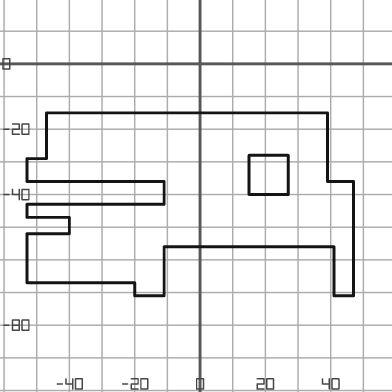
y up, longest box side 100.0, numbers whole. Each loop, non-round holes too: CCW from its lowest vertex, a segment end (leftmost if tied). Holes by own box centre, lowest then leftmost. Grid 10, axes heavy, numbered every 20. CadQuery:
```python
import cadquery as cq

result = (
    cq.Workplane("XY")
    .moveTo(-20.0, -71.0)
    .lineTo(-11.0, -71.0)
    .lineTo(-11.0, -56.0)
    .lineTo(41.0, -56.0)
    .lineTo(41.0, -71.0)
    .lineTo(47.0, -71.0)
    .lineTo(47.0, -36.0)
    .lineTo(39.0, -36.0)
    .lineTo(39.0, -15.0)
    .lineTo(-47.0, -15.0)
    .lineTo(-47.0, -29.0)
    .lineTo(-53.0, -29.0)
    .lineTo(-53.0, -36.0)
    .lineTo(-11.0, -36.0)
    .lineTo(-11.0, -43.0)
    .lineTo(-53.0, -43.0)
    .lineTo(-53.0, -47.0)
    .lineTo(-40.0, -47.0)
    .lineTo(-40.0, -52.0)
    .lineTo(-53.0, -52.0)
    .lineTo(-53.0, -67.0)
    .lineTo(-20.0, -67.0)
    .close()
    .moveTo(15.0, -40.0)
    .lineTo(27.0, -40.0)
    .lineTo(27.0, -28.0)
    .lineTo(15.0, -28.0)
    .close()
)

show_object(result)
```